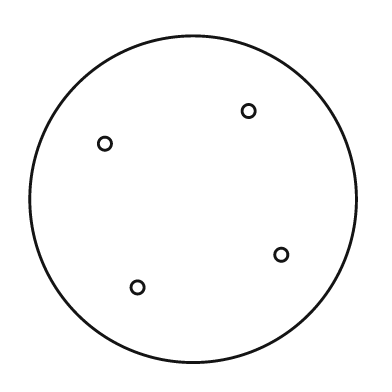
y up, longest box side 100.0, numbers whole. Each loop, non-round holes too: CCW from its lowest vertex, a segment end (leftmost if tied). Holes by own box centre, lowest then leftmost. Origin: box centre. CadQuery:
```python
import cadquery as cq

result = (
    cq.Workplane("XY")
    .moveTo(0.0, 0.0)
    .circle(50.0)
    .moveTo(-17.0, -27.0)
    .circle(2.0)
    .moveTo(27.0, -17.0)
    .circle(2.0)
    .moveTo(-27.0, 17.0)
    .circle(2.0)
    .moveTo(17.0, 27.0)
    .circle(2.0)
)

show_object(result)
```